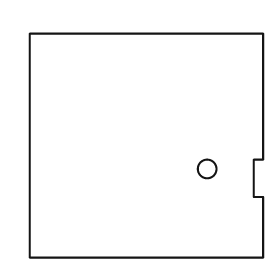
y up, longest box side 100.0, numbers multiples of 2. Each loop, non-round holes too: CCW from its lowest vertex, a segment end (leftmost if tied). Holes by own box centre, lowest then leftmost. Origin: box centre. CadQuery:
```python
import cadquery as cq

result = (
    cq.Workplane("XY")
    .moveTo(-50.0, -48.0)
    .lineTo(50.0, -48.0)
    .lineTo(50.0, -22.0)
    .lineTo(46.0, -22.0)
    .lineTo(46.0, -6.0)
    .lineTo(50.0, -6.0)
    .lineTo(50.0, 48.0)
    .lineTo(-50.0, 48.0)
    .close()
    .moveTo(26.0, -10.0)
    .circle(4.0)
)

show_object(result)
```